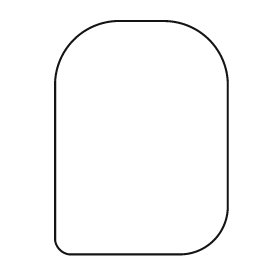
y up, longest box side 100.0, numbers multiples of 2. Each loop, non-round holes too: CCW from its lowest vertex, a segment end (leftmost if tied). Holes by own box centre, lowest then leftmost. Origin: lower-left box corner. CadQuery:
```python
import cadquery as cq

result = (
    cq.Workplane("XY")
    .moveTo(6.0, 0.0)
    .lineTo(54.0, 0.0)
    .threePointArc((68.0, 6.0), (74.0, 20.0))
    .lineTo(74.0, 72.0)
    .threePointArc((66.0, 92.0), (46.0, 100.0))
    .lineTo(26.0, 100.0)
    .threePointArc((8.0, 92.0), (0.0, 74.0))
    .lineTo(0.0, 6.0)
    .threePointArc((2.0, 2.0), (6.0, 0.0))
    .close()
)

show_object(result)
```